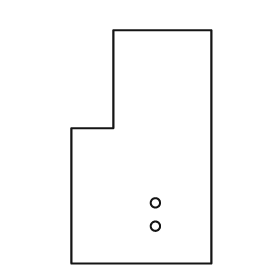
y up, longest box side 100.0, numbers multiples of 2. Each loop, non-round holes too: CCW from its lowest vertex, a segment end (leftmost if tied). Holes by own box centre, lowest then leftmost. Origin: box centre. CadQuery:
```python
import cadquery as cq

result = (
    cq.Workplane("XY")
    .moveTo(-30.0, -50.0)
    .lineTo(30.0, -50.0)
    .lineTo(30.0, 50.0)
    .lineTo(-12.0, 50.0)
    .lineTo(-12.0, 8.0)
    .lineTo(-30.0, 8.0)
    .close()
    .moveTo(6.0, -34.0)
    .circle(2.0)
    .moveTo(6.0, -24.0)
    .circle(2.0)
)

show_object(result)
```